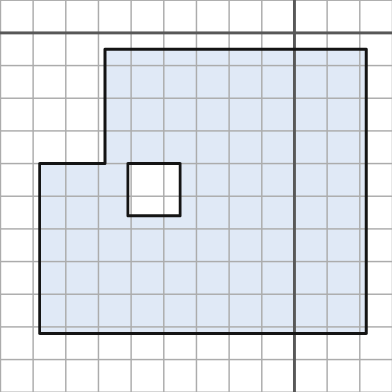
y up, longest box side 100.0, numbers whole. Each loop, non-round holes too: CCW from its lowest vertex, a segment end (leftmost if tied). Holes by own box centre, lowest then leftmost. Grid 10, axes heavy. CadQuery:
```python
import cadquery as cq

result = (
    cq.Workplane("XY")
    .moveTo(-78.0, -92.0)
    .lineTo(22.0, -92.0)
    .lineTo(22.0, -5.0)
    .lineTo(-58.0, -5.0)
    .lineTo(-58.0, -40.0)
    .lineTo(-78.0, -40.0)
    .close()
    .moveTo(-51.0, -56.0)
    .lineTo(-35.0, -56.0)
    .lineTo(-35.0, -40.0)
    .lineTo(-51.0, -40.0)
    .close()
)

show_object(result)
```